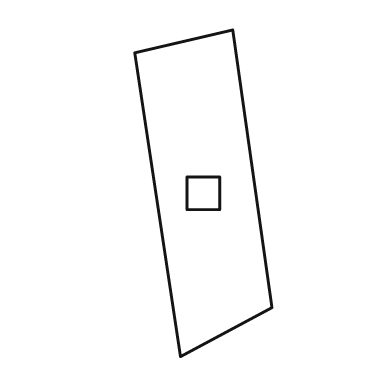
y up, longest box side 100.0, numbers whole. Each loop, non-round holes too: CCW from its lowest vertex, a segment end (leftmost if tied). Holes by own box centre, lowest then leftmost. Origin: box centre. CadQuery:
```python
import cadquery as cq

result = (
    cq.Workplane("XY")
    .moveTo(-7.0, -50.0)
    .lineTo(21.0, -35.0)
    .lineTo(9.0, 50.0)
    .lineTo(-21.0, 43.0)
    .close()
    .moveTo(-5.0, -5.0)
    .lineTo(5.0, -5.0)
    .lineTo(5.0, 5.0)
    .lineTo(-5.0, 5.0)
    .close()
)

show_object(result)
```